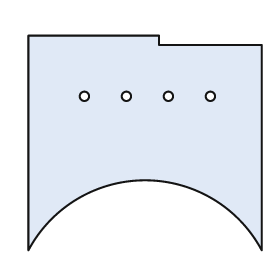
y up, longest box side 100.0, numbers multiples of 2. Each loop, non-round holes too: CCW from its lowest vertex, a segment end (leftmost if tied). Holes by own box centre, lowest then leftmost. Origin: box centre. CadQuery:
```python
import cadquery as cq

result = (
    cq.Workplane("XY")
    .moveTo(-50.0, -46.0)
    .threePointArc((0.0, -16.0), (50.0, -46.0))
    .lineTo(50.0, 42.0)
    .lineTo(6.0, 42.0)
    .lineTo(6.0, 46.0)
    .lineTo(-50.0, 46.0)
    .close()
    .moveTo(-26.0, 20.0)
    .circle(2.0)
    .moveTo(-8.0, 20.0)
    .circle(2.0)
    .moveTo(10.0, 20.0)
    .circle(2.0)
    .moveTo(28.0, 20.0)
    .circle(2.0)
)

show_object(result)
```